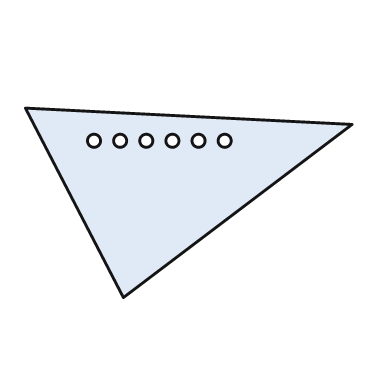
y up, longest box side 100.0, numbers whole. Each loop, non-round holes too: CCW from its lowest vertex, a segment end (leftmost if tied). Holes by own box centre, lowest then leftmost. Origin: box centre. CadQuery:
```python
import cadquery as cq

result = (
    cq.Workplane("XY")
    .moveTo(-20.0, -29.0)
    .lineTo(50.0, 24.0)
    .lineTo(-50.0, 29.0)
    .close()
    .moveTo(-29.0, 19.0)
    .circle(2.0)
    .moveTo(-21.0, 19.0)
    .circle(2.0)
    .moveTo(-13.0, 19.0)
    .circle(2.0)
    .moveTo(-5.0, 19.0)
    .circle(2.0)
    .moveTo(3.0, 19.0)
    .circle(2.0)
    .moveTo(11.0, 19.0)
    .circle(2.0)
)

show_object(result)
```